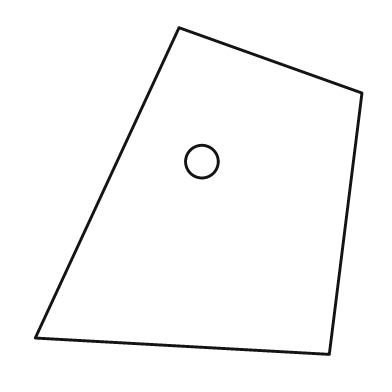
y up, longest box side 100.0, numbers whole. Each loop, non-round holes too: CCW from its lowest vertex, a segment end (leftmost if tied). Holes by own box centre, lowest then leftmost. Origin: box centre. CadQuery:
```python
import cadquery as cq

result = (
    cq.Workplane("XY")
    .moveTo(40.0, -50.0)
    .lineTo(50.0, 30.0)
    .lineTo(-6.0, 50.0)
    .lineTo(-50.0, -45.0)
    .close()
    .moveTo(1.0, 9.0)
    .circle(5.0)
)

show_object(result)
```